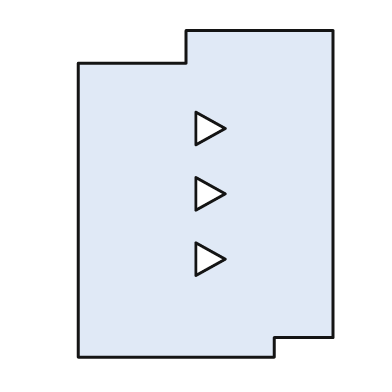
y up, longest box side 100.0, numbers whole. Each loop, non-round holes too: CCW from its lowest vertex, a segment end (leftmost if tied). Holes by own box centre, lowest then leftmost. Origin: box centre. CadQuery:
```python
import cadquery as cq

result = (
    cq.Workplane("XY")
    .moveTo(-39.0, -50.0)
    .lineTo(21.0, -50.0)
    .lineTo(21.0, -44.0)
    .lineTo(39.0, -44.0)
    .lineTo(39.0, 50.0)
    .lineTo(-6.0, 50.0)
    .lineTo(-6.0, 40.0)
    .lineTo(-39.0, 40.0)
    .close()
    .moveTo(-3.0, -25.0)
    .lineTo(6.0, -20.0)
    .lineTo(-3.0, -15.0)
    .close()
    .moveTo(-3.0, -5.0)
    .lineTo(6.0, 0.0)
    .lineTo(-3.0, 5.0)
    .close()
    .moveTo(-3.0, 15.0)
    .lineTo(6.0, 20.0)
    .lineTo(-3.0, 25.0)
    .close()
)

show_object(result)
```